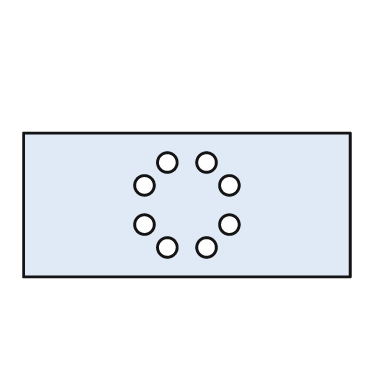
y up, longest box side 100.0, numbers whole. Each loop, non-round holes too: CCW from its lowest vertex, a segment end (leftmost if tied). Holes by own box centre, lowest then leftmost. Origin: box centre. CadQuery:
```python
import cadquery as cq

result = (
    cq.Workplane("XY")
    .moveTo(-50.0, -22.0)
    .lineTo(50.0, -22.0)
    .lineTo(50.0, 22.0)
    .lineTo(-50.0, 22.0)
    .close()
    .moveTo(-6.0, -13.0)
    .circle(3.0)
    .moveTo(6.0, -13.0)
    .circle(3.0)
    .moveTo(-13.0, -6.0)
    .circle(3.0)
    .moveTo(13.0, -6.0)
    .circle(3.0)
    .moveTo(-13.0, 6.0)
    .circle(3.0)
    .moveTo(13.0, 6.0)
    .circle(3.0)
    .moveTo(-6.0, 13.0)
    .circle(3.0)
    .moveTo(6.0, 13.0)
    .circle(3.0)
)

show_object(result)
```